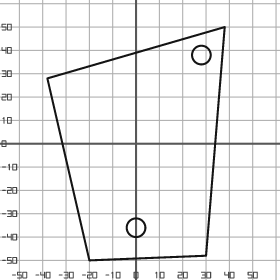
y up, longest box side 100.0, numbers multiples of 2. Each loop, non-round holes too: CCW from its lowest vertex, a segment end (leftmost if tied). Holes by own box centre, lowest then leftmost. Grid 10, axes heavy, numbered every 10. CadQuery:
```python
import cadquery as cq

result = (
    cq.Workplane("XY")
    .moveTo(-20.0, -50.0)
    .lineTo(30.0, -48.0)
    .lineTo(38.0, 50.0)
    .lineTo(-38.0, 28.0)
    .close()
    .moveTo(0.0, -36.0)
    .circle(4.0)
    .moveTo(28.0, 38.0)
    .circle(4.0)
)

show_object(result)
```